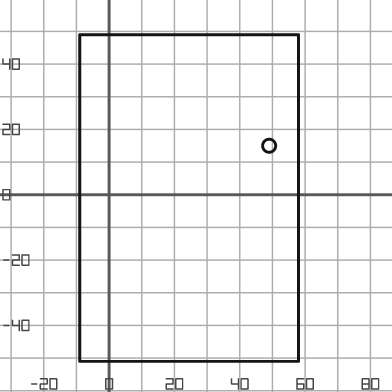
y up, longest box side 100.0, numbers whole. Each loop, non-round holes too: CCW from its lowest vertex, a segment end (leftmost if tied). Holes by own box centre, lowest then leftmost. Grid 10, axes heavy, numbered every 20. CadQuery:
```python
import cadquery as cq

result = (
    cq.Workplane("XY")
    .moveTo(-9.0, -51.0)
    .lineTo(58.0, -51.0)
    .lineTo(58.0, 49.0)
    .lineTo(-9.0, 49.0)
    .close()
    .moveTo(49.0, 15.0)
    .circle(2.0)
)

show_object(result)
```